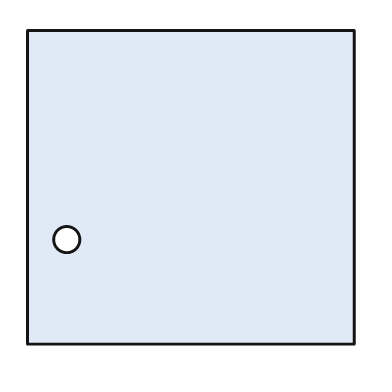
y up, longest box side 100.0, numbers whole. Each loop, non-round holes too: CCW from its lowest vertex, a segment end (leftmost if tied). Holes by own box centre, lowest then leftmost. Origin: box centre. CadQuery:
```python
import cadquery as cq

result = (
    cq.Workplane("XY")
    .moveTo(-50.0, -48.0)
    .lineTo(50.0, -48.0)
    .lineTo(50.0, 48.0)
    .lineTo(-50.0, 48.0)
    .close()
    .moveTo(-38.0, -16.0)
    .circle(4.0)
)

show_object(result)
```